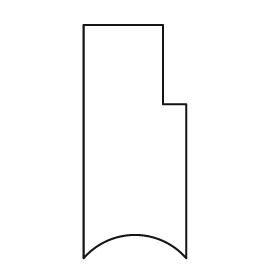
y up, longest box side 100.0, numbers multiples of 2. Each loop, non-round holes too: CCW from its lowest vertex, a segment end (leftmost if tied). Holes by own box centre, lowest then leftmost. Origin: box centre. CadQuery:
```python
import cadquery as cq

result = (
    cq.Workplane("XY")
    .moveTo(-22.0, -50.0)
    .threePointArc((0.0, -40.0), (22.0, -50.0))
    .lineTo(22.0, 16.0)
    .lineTo(12.0, 16.0)
    .lineTo(12.0, 50.0)
    .lineTo(-22.0, 50.0)
    .close()
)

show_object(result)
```